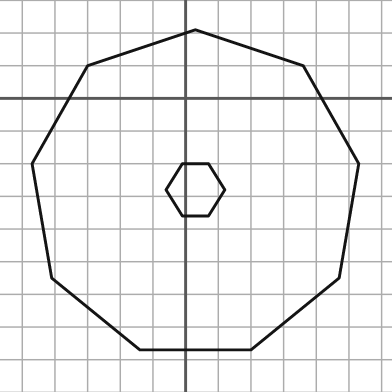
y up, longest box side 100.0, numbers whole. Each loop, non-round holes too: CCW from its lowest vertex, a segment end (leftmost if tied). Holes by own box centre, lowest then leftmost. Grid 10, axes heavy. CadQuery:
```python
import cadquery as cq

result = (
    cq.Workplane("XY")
    .moveTo(-14.0, -77.0)
    .lineTo(20.0, -77.0)
    .lineTo(47.0, -55.0)
    .lineTo(53.0, -20.0)
    .lineTo(36.0, 10.0)
    .lineTo(3.0, 21.0)
    .lineTo(-30.0, 10.0)
    .lineTo(-47.0, -20.0)
    .lineTo(-41.0, -55.0)
    .close()
    .moveTo(-1.0, -36.0)
    .lineTo(7.0, -36.0)
    .lineTo(12.0, -28.0)
    .lineTo(7.0, -20.0)
    .lineTo(-1.0, -20.0)
    .lineTo(-6.0, -28.0)
    .close()
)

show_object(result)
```